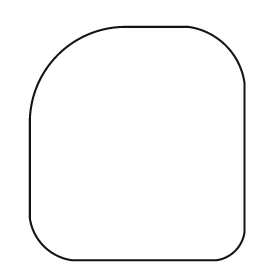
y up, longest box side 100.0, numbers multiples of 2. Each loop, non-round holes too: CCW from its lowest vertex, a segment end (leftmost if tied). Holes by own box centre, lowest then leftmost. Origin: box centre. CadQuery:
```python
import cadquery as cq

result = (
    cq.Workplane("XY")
    .moveTo(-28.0, -50.0)
    .lineTo(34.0, -50.0)
    .threePointArc((42.0, -46.0), (46.0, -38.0))
    .lineTo(46.0, 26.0)
    .threePointArc((38.0, 42.0), (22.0, 50.0))
    .lineTo(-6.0, 50.0)
    .threePointArc((-34.0, 38.0), (-46.0, 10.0))
    .lineTo(-46.0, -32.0)
    .threePointArc((-40.0, -44.0), (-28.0, -50.0))
    .close()
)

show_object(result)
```